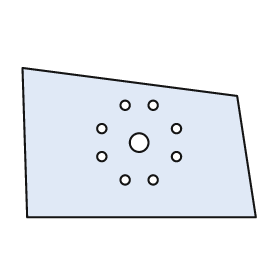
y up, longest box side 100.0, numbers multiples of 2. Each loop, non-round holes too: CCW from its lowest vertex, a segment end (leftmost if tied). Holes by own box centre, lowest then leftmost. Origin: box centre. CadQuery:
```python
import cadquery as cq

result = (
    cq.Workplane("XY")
    .moveTo(-48.0, -32.0)
    .lineTo(50.0, -32.0)
    .lineTo(42.0, 20.0)
    .lineTo(-50.0, 32.0)
    .close()
    .moveTo(-6.0, -16.0)
    .circle(2.0)
    .moveTo(6.0, -16.0)
    .circle(2.0)
    .moveTo(-16.0, -6.0)
    .circle(2.0)
    .moveTo(16.0, -6.0)
    .circle(2.0)
    .moveTo(0.0, 0.0)
    .circle(4.0)
    .moveTo(-16.0, 6.0)
    .circle(2.0)
    .moveTo(16.0, 6.0)
    .circle(2.0)
    .moveTo(-6.0, 16.0)
    .circle(2.0)
    .moveTo(6.0, 16.0)
    .circle(2.0)
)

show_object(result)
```